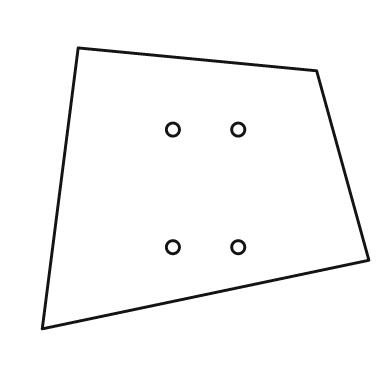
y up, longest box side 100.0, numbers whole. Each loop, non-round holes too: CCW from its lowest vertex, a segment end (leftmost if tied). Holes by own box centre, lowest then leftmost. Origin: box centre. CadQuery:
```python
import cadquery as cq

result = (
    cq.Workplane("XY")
    .moveTo(-50.0, -43.0)
    .lineTo(50.0, -22.0)
    .lineTo(34.0, 36.0)
    .lineTo(-39.0, 43.0)
    .close()
    .moveTo(-10.0, -18.0)
    .circle(2.0)
    .moveTo(10.0, -18.0)
    .circle(2.0)
    .moveTo(-10.0, 18.0)
    .circle(2.0)
    .moveTo(10.0, 18.0)
    .circle(2.0)
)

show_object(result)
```